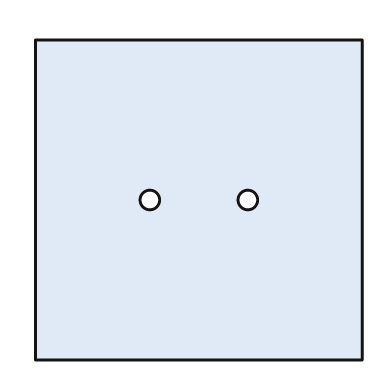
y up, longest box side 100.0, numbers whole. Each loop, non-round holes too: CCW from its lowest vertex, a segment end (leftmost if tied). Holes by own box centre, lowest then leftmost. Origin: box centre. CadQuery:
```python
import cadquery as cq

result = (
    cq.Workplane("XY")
    .moveTo(-50.0, -49.0)
    .lineTo(50.0, -49.0)
    .lineTo(50.0, 49.0)
    .lineTo(-50.0, 49.0)
    .close()
    .moveTo(-15.0, 0.0)
    .circle(3.0)
    .moveTo(15.0, 0.0)
    .circle(3.0)
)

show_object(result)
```